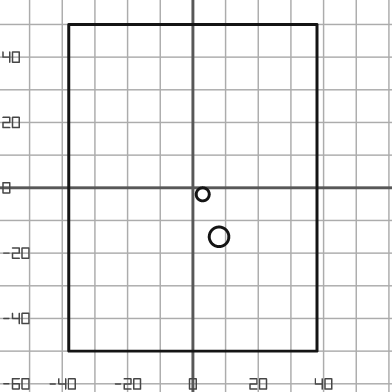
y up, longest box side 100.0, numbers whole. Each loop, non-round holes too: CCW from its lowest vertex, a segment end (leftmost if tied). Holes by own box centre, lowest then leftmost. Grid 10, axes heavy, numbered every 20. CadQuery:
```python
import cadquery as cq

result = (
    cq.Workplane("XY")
    .moveTo(-38.0, -50.0)
    .lineTo(38.0, -50.0)
    .lineTo(38.0, 50.0)
    .lineTo(-38.0, 50.0)
    .close()
    .moveTo(8.0, -15.0)
    .circle(3.0)
    .moveTo(3.0, -2.0)
    .circle(2.0)
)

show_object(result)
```